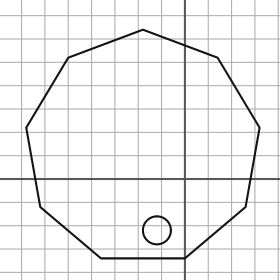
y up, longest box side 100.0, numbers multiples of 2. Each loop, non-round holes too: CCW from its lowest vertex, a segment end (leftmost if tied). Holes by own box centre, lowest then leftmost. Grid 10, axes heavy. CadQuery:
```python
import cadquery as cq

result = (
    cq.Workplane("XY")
    .moveTo(-36.0, -34.0)
    .lineTo(0.0, -34.0)
    .lineTo(26.0, -12.0)
    .lineTo(32.0, 22.0)
    .lineTo(14.0, 52.0)
    .lineTo(-18.0, 64.0)
    .lineTo(-50.0, 52.0)
    .lineTo(-68.0, 22.0)
    .lineTo(-62.0, -12.0)
    .close()
    .moveTo(-12.0, -22.0)
    .circle(6.0)
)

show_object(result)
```